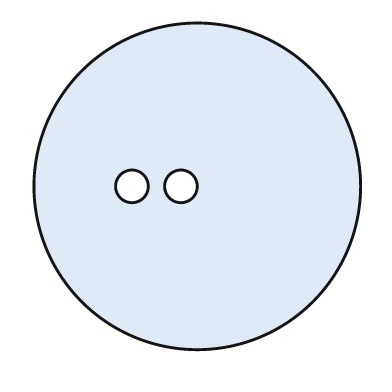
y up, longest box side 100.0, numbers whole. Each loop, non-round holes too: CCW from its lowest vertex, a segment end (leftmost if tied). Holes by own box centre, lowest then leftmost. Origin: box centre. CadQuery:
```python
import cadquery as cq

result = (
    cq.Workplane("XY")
    .moveTo(0.0, 0.0)
    .circle(50.0)
    .moveTo(-20.0, 0.0)
    .circle(5.0)
    .moveTo(-5.0, 0.0)
    .circle(5.0)
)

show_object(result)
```